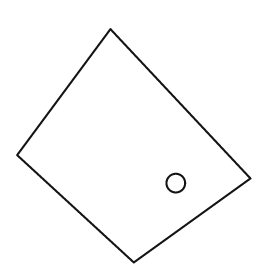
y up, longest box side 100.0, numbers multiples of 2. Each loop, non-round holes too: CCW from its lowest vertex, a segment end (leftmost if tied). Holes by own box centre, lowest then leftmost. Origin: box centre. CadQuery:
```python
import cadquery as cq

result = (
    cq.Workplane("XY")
    .moveTo(0.0, -50.0)
    .lineTo(50.0, -14.0)
    .lineTo(-10.0, 50.0)
    .lineTo(-50.0, -4.0)
    .close()
    .moveTo(18.0, -16.0)
    .circle(4.0)
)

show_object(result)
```